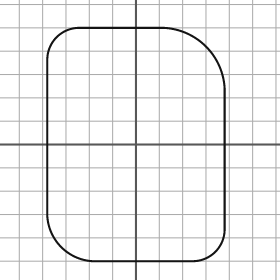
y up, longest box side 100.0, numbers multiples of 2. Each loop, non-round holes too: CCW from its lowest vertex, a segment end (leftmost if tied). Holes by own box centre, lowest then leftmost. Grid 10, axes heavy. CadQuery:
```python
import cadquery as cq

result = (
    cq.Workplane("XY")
    .moveTo(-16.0, -50.0)
    .lineTo(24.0, -50.0)
    .threePointArc((34.0, -46.0), (38.0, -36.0))
    .lineTo(38.0, 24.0)
    .threePointArc((30.0, 42.0), (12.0, 50.0))
    .lineTo(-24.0, 50.0)
    .threePointArc((-34.0, 46.0), (-38.0, 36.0))
    .lineTo(-38.0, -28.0)
    .threePointArc((-32.0, -44.0), (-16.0, -50.0))
    .close()
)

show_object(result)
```